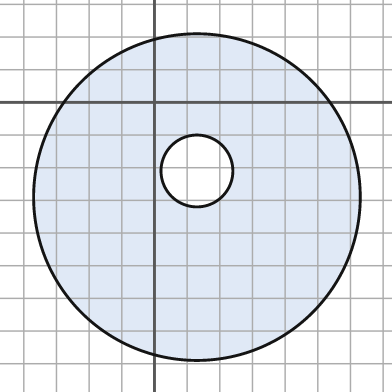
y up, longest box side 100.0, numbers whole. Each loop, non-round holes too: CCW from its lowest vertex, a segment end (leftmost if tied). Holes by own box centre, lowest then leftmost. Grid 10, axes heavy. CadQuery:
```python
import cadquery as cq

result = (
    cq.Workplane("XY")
    .moveTo(13.0, -29.0)
    .circle(50.0)
    .moveTo(13.0, -21.0)
    .circle(11.0)
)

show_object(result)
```